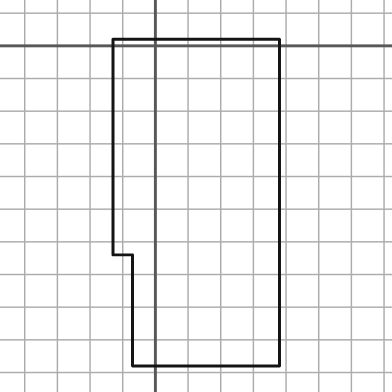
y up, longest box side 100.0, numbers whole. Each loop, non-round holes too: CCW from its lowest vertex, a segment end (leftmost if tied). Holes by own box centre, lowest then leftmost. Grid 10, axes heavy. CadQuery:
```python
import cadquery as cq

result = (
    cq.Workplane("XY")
    .moveTo(-7.0, -98.0)
    .lineTo(38.0, -98.0)
    .lineTo(38.0, 2.0)
    .lineTo(-13.0, 2.0)
    .lineTo(-13.0, -64.0)
    .lineTo(-7.0, -64.0)
    .close()
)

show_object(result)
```